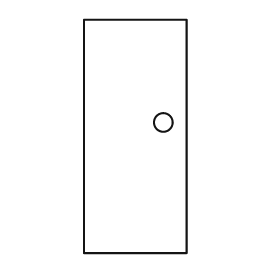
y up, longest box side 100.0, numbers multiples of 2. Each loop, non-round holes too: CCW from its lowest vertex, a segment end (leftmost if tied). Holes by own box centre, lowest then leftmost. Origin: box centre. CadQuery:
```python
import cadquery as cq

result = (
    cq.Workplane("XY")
    .moveTo(-22.0, -50.0)
    .lineTo(22.0, -50.0)
    .lineTo(22.0, 50.0)
    .lineTo(-22.0, 50.0)
    .close()
    .moveTo(12.0, 6.0)
    .circle(4.0)
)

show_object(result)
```